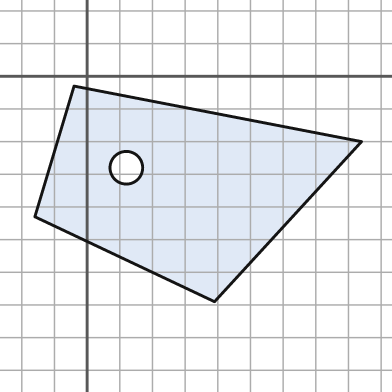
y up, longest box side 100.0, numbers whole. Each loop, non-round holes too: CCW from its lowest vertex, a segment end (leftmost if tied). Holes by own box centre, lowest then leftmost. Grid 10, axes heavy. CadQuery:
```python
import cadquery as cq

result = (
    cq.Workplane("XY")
    .moveTo(39.0, -69.0)
    .lineTo(84.0, -20.0)
    .lineTo(-4.0, -3.0)
    .lineTo(-16.0, -43.0)
    .close()
    .moveTo(12.0, -28.0)
    .circle(5.0)
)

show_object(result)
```